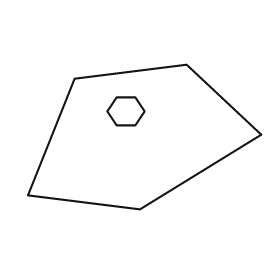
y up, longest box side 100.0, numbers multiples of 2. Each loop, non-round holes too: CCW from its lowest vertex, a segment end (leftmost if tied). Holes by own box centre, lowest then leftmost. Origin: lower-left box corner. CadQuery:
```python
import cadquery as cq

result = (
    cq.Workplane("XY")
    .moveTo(48.0, 0.0)
    .lineTo(100.0, 32.0)
    .lineTo(68.0, 62.0)
    .lineTo(20.0, 56.0)
    .lineTo(0.0, 6.0)
    .close()
    .moveTo(38.0, 36.0)
    .lineTo(46.0, 36.0)
    .lineTo(50.0, 42.0)
    .lineTo(46.0, 48.0)
    .lineTo(38.0, 48.0)
    .lineTo(34.0, 42.0)
    .close()
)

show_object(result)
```